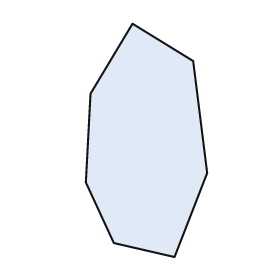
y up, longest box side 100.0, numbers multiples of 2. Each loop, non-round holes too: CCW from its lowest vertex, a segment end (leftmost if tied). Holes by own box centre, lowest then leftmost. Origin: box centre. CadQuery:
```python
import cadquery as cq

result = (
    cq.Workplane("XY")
    .moveTo(12.0, -50.0)
    .lineTo(26.0, -14.0)
    .lineTo(20.0, 34.0)
    .lineTo(-6.0, 50.0)
    .lineTo(-24.0, 20.0)
    .lineTo(-26.0, -18.0)
    .lineTo(-14.0, -44.0)
    .close()
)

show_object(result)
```